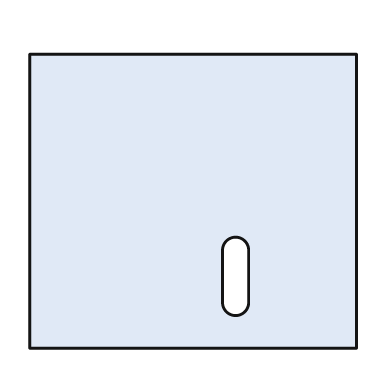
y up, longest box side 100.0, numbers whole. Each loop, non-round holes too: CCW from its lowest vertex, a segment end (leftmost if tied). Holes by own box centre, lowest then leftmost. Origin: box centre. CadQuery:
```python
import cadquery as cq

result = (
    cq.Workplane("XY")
    .moveTo(-50.0, -45.0)
    .lineTo(50.0, -45.0)
    .lineTo(50.0, 45.0)
    .lineTo(-50.0, 45.0)
    .close()
    .moveTo(9.0, -31.0)
    .threePointArc((13.0, -35.0), (17.0, -31.0))
    .lineTo(17.0, -15.0)
    .threePointArc((13.0, -11.0), (9.0, -15.0))
    .close()
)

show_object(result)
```